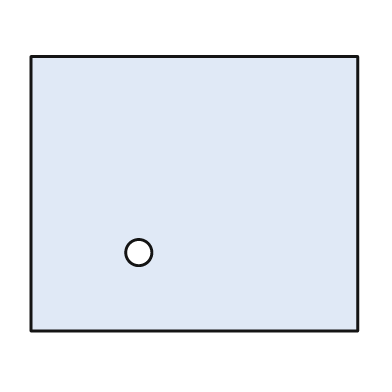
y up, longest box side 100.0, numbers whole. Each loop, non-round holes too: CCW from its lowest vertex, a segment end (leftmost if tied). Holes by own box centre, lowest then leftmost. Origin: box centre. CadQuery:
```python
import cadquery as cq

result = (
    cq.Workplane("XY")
    .moveTo(-50.0, -42.0)
    .lineTo(50.0, -42.0)
    .lineTo(50.0, 42.0)
    .lineTo(-50.0, 42.0)
    .close()
    .moveTo(-17.0, -18.0)
    .circle(4.0)
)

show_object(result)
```